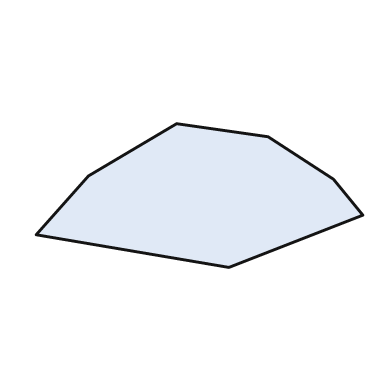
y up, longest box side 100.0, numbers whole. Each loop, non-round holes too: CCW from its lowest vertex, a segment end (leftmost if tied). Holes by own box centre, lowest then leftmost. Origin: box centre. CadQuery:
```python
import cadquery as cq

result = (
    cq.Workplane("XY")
    .moveTo(9.0, -22.0)
    .lineTo(50.0, -6.0)
    .lineTo(41.0, 5.0)
    .lineTo(21.0, 18.0)
    .lineTo(-7.0, 22.0)
    .lineTo(-34.0, 6.0)
    .lineTo(-50.0, -12.0)
    .close()
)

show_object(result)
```